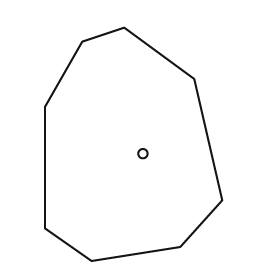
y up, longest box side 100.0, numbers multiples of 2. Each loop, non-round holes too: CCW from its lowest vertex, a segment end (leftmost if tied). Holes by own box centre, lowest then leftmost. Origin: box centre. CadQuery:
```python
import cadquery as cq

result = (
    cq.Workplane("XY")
    .moveTo(-18.0, -50.0)
    .lineTo(20.0, -44.0)
    .lineTo(38.0, -24.0)
    .lineTo(26.0, 28.0)
    .lineTo(-4.0, 50.0)
    .lineTo(-22.0, 44.0)
    .lineTo(-38.0, 16.0)
    .lineTo(-38.0, -36.0)
    .close()
    .moveTo(4.0, -4.0)
    .circle(2.0)
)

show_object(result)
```